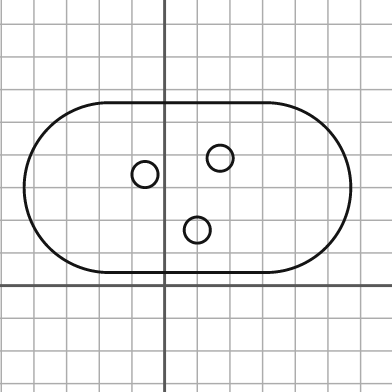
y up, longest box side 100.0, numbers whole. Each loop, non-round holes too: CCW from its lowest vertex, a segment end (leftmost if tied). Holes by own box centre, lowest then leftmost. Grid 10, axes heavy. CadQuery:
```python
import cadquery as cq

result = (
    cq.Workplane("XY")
    .moveTo(-17.0, 4.0)
    .lineTo(31.0, 4.0)
    .threePointArc((57.0, 30.0), (31.0, 56.0))
    .lineTo(-17.0, 56.0)
    .threePointArc((-43.0, 30.0), (-17.0, 4.0))
    .close()
    .moveTo(10.0, 17.0)
    .circle(4.0)
    .moveTo(-6.0, 34.0)
    .circle(4.0)
    .moveTo(17.0, 39.0)
    .circle(4.0)
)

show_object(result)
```